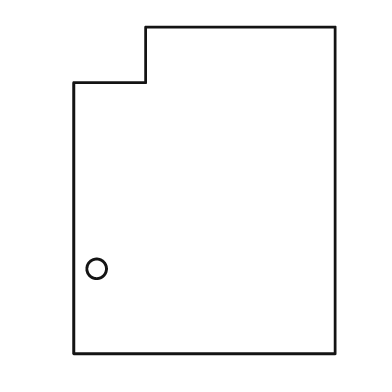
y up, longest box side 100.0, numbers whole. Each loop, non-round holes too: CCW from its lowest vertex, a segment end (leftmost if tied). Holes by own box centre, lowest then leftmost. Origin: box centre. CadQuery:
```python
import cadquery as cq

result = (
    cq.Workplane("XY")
    .moveTo(-40.0, -50.0)
    .lineTo(40.0, -50.0)
    .lineTo(40.0, 50.0)
    .lineTo(-18.0, 50.0)
    .lineTo(-18.0, 33.0)
    .lineTo(-40.0, 33.0)
    .close()
    .moveTo(-33.0, -24.0)
    .circle(3.0)
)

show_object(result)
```